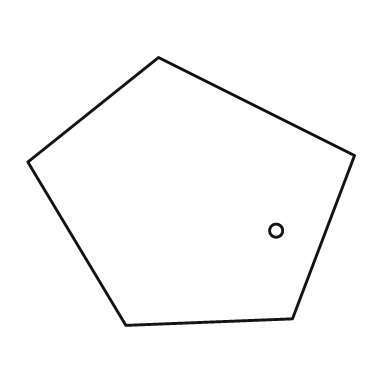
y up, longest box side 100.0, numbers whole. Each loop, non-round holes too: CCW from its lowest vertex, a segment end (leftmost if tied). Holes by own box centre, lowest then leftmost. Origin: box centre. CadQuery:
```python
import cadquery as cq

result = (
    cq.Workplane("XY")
    .moveTo(-20.0, -41.0)
    .lineTo(31.0, -39.0)
    .lineTo(50.0, 11.0)
    .lineTo(-10.0, 41.0)
    .lineTo(-50.0, 9.0)
    .close()
    .moveTo(26.0, -12.0)
    .circle(2.0)
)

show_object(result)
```